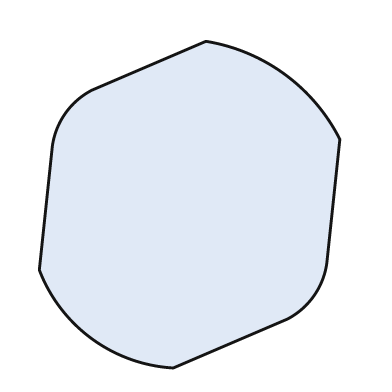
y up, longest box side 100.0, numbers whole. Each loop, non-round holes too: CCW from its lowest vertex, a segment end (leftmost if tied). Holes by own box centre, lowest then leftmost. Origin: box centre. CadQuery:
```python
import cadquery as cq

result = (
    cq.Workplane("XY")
    .moveTo(-5.0, -50.0)
    .lineTo(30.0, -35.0)
    .threePointArc((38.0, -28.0), (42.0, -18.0))
    .lineTo(46.0, 20.0)
    .threePointArc((29.0, 40.0), (5.0, 50.0))
    .lineTo(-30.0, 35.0)
    .threePointArc((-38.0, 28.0), (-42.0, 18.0))
    .lineTo(-46.0, -20.0)
    .threePointArc((-30.0, -41.0), (-5.0, -50.0))
    .close()
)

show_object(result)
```